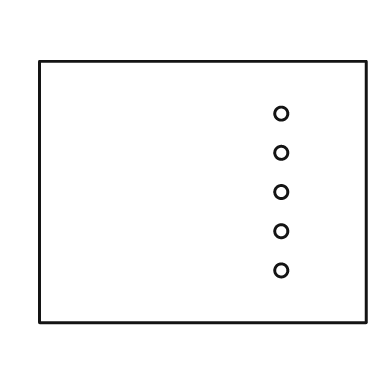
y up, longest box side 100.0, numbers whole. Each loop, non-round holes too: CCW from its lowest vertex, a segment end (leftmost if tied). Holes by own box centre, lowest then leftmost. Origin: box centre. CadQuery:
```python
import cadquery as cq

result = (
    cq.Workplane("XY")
    .moveTo(-50.0, -40.0)
    .lineTo(50.0, -40.0)
    .lineTo(50.0, 40.0)
    .lineTo(-50.0, 40.0)
    .close()
    .moveTo(24.0, -24.0)
    .circle(2.0)
    .moveTo(24.0, -12.0)
    .circle(2.0)
    .moveTo(24.0, 0.0)
    .circle(2.0)
    .moveTo(24.0, 12.0)
    .circle(2.0)
    .moveTo(24.0, 24.0)
    .circle(2.0)
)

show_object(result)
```